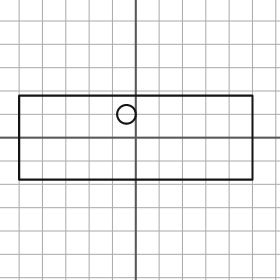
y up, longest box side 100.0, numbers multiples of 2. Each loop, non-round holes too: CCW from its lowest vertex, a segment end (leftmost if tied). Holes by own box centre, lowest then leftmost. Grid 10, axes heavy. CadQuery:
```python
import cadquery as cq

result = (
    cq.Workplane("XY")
    .moveTo(-50.0, -18.0)
    .lineTo(50.0, -18.0)
    .lineTo(50.0, 18.0)
    .lineTo(-50.0, 18.0)
    .close()
    .moveTo(-4.0, 10.0)
    .circle(4.0)
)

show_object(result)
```